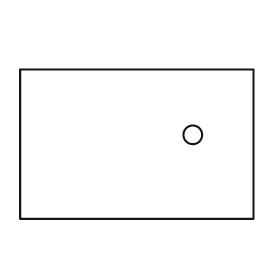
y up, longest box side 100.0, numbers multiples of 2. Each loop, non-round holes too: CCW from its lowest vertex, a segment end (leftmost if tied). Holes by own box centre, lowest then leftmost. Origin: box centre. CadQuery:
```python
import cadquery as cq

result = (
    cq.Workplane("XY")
    .moveTo(-50.0, -32.0)
    .lineTo(50.0, -32.0)
    .lineTo(50.0, 32.0)
    .lineTo(-50.0, 32.0)
    .close()
    .moveTo(24.0, 4.0)
    .circle(4.0)
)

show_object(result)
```